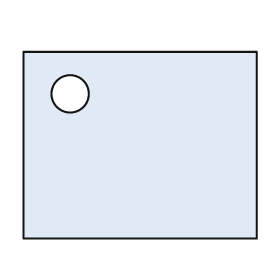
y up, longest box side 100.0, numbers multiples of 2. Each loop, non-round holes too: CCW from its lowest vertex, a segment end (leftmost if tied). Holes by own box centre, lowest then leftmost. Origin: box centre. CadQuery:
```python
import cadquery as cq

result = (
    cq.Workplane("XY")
    .moveTo(-50.0, -40.0)
    .lineTo(50.0, -40.0)
    .lineTo(50.0, 40.0)
    .lineTo(-50.0, 40.0)
    .close()
    .moveTo(-30.0, 22.0)
    .circle(8.0)
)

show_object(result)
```